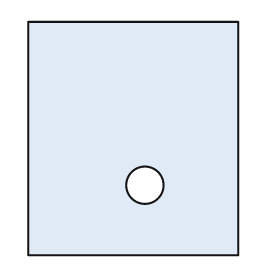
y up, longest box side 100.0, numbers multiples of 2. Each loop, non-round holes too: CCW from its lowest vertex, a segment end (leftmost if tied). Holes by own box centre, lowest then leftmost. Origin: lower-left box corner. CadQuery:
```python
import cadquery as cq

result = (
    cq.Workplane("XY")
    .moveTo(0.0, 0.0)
    .lineTo(90.0, 0.0)
    .lineTo(90.0, 100.0)
    .lineTo(0.0, 100.0)
    .close()
    .moveTo(50.0, 30.0)
    .circle(8.0)
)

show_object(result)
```